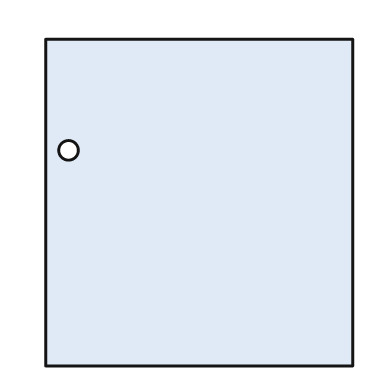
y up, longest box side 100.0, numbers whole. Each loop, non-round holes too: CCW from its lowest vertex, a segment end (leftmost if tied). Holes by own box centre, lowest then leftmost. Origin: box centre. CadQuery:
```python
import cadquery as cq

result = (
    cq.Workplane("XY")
    .moveTo(-47.0, -50.0)
    .lineTo(47.0, -50.0)
    .lineTo(47.0, 50.0)
    .lineTo(-47.0, 50.0)
    .close()
    .moveTo(-40.0, 16.0)
    .circle(3.0)
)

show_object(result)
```